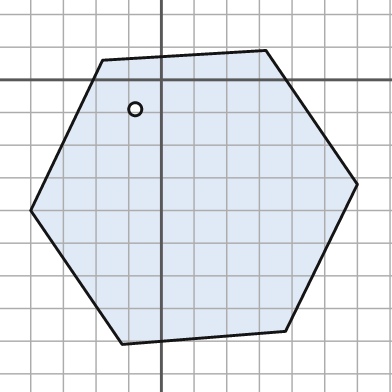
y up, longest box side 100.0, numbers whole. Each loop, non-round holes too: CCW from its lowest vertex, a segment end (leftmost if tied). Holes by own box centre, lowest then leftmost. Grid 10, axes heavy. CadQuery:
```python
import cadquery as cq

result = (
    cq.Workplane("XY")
    .moveTo(-12.0, -81.0)
    .lineTo(38.0, -77.0)
    .lineTo(60.0, -32.0)
    .lineTo(32.0, 9.0)
    .lineTo(-18.0, 6.0)
    .lineTo(-40.0, -40.0)
    .close()
    .moveTo(-8.0, -9.0)
    .circle(2.0)
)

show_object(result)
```